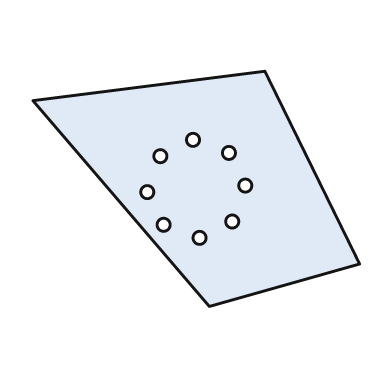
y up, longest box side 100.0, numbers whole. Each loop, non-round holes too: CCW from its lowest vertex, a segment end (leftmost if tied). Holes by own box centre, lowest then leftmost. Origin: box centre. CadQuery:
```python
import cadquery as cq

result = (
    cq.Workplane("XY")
    .moveTo(4.0, -36.0)
    .lineTo(50.0, -23.0)
    .lineTo(21.0, 36.0)
    .lineTo(-50.0, 27.0)
    .close()
    .moveTo(1.0, -15.0)
    .circle(2.0)
    .moveTo(-10.0, -11.0)
    .circle(2.0)
    .moveTo(11.0, -10.0)
    .circle(2.0)
    .moveTo(-15.0, -1.0)
    .circle(2.0)
    .moveTo(15.0, 1.0)
    .circle(2.0)
    .moveTo(-11.0, 10.0)
    .circle(2.0)
    .moveTo(10.0, 11.0)
    .circle(2.0)
    .moveTo(-1.0, 15.0)
    .circle(2.0)
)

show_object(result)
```